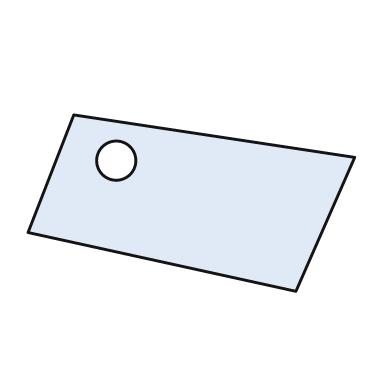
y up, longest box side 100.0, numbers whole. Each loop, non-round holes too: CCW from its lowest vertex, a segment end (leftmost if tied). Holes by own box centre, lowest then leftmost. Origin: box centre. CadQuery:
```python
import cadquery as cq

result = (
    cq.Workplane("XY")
    .moveTo(32.0, -27.0)
    .lineTo(50.0, 14.0)
    .lineTo(-36.0, 27.0)
    .lineTo(-50.0, -9.0)
    .close()
    .moveTo(-23.0, 13.0)
    .circle(6.0)
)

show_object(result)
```